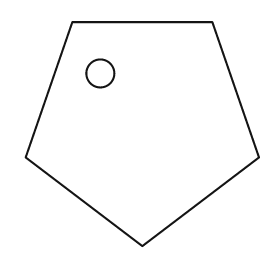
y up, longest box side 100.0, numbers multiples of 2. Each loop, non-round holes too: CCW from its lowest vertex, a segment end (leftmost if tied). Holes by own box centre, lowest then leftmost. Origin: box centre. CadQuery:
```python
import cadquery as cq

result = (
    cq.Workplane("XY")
    .moveTo(0.0, -48.0)
    .lineTo(50.0, -10.0)
    .lineTo(30.0, 48.0)
    .lineTo(-30.0, 48.0)
    .lineTo(-50.0, -10.0)
    .close()
    .moveTo(-18.0, 26.0)
    .circle(6.0)
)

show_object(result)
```